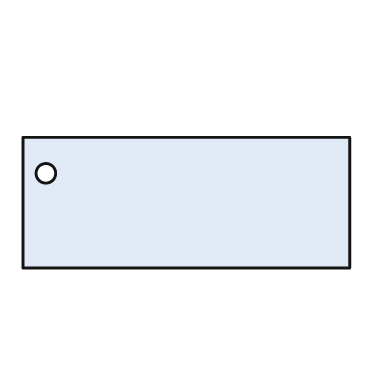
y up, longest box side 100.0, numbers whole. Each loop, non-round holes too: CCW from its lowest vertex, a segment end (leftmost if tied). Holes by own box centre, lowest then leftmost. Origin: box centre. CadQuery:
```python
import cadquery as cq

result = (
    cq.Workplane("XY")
    .moveTo(-50.0, -20.0)
    .lineTo(50.0, -20.0)
    .lineTo(50.0, 20.0)
    .lineTo(-50.0, 20.0)
    .close()
    .moveTo(-43.0, 9.0)
    .circle(3.0)
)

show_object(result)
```